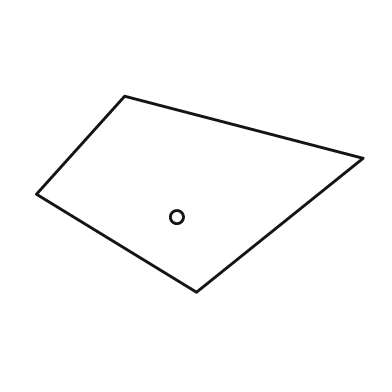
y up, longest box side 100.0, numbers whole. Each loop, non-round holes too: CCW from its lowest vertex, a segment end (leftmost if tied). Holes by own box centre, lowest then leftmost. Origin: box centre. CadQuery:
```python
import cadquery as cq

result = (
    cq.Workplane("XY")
    .moveTo(-1.0, -30.0)
    .lineTo(50.0, 11.0)
    .lineTo(-23.0, 30.0)
    .lineTo(-50.0, 0.0)
    .close()
    .moveTo(-7.0, -7.0)
    .circle(2.0)
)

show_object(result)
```